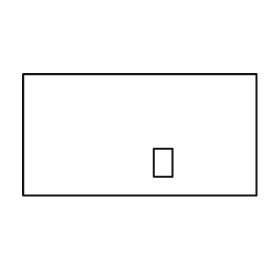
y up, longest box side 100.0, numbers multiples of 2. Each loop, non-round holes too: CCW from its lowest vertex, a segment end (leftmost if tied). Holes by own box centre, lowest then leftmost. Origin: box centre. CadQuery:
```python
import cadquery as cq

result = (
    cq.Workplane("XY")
    .moveTo(-50.0, -26.0)
    .lineTo(50.0, -26.0)
    .lineTo(50.0, 26.0)
    .lineTo(-50.0, 26.0)
    .close()
    .moveTo(6.0, -18.0)
    .lineTo(14.0, -18.0)
    .lineTo(14.0, -6.0)
    .lineTo(6.0, -6.0)
    .close()
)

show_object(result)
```